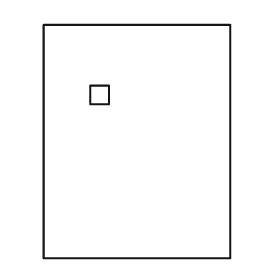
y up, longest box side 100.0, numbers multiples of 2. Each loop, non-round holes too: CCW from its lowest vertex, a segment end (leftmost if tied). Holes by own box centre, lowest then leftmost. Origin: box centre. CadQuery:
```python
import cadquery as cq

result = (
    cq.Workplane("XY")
    .moveTo(-40.0, -50.0)
    .lineTo(40.0, -50.0)
    .lineTo(40.0, 50.0)
    .lineTo(-40.0, 50.0)
    .close()
    .moveTo(-20.0, 16.0)
    .lineTo(-12.0, 16.0)
    .lineTo(-12.0, 24.0)
    .lineTo(-20.0, 24.0)
    .close()
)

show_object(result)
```